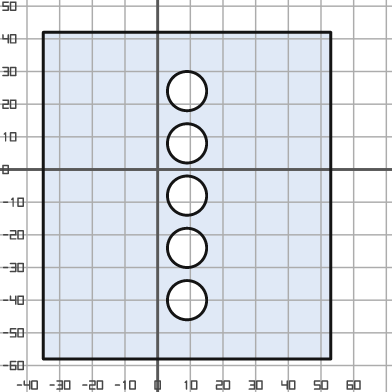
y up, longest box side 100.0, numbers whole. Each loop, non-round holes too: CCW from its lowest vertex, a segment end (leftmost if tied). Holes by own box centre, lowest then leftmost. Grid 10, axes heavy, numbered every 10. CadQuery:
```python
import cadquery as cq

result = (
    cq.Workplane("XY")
    .moveTo(-35.0, -58.0)
    .lineTo(53.0, -58.0)
    .lineTo(53.0, 42.0)
    .lineTo(-35.0, 42.0)
    .close()
    .moveTo(9.0, -40.0)
    .circle(6.0)
    .moveTo(9.0, -24.0)
    .circle(6.0)
    .moveTo(9.0, -8.0)
    .circle(6.0)
    .moveTo(9.0, 8.0)
    .circle(6.0)
    .moveTo(9.0, 24.0)
    .circle(6.0)
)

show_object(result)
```